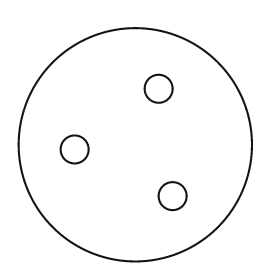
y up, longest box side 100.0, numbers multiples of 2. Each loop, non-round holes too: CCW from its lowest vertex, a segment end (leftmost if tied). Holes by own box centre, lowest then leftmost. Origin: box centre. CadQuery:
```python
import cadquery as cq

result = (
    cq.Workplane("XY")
    .moveTo(0.0, 0.0)
    .circle(50.0)
    .moveTo(16.0, -22.0)
    .circle(6.0)
    .moveTo(-26.0, -2.0)
    .circle(6.0)
    .moveTo(10.0, 24.0)
    .circle(6.0)
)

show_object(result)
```